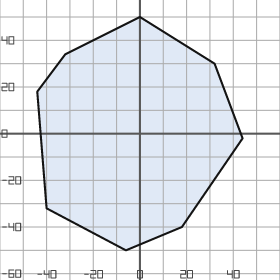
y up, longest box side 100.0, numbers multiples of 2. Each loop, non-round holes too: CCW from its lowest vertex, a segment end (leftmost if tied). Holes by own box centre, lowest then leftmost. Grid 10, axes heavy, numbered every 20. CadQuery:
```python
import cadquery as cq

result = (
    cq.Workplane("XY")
    .moveTo(-6.0, -50.0)
    .lineTo(18.0, -40.0)
    .lineTo(44.0, -2.0)
    .lineTo(32.0, 30.0)
    .lineTo(0.0, 50.0)
    .lineTo(-32.0, 34.0)
    .lineTo(-44.0, 18.0)
    .lineTo(-40.0, -32.0)
    .close()
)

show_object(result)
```